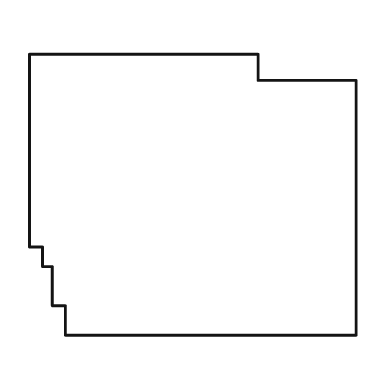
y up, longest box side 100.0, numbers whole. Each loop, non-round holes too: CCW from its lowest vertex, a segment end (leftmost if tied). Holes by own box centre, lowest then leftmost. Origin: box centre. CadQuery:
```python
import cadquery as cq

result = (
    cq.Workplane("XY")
    .moveTo(-39.0, -43.0)
    .lineTo(50.0, -43.0)
    .lineTo(50.0, 35.0)
    .lineTo(20.0, 35.0)
    .lineTo(20.0, 43.0)
    .lineTo(-50.0, 43.0)
    .lineTo(-50.0, -16.0)
    .lineTo(-46.0, -16.0)
    .lineTo(-46.0, -22.0)
    .lineTo(-43.0, -22.0)
    .lineTo(-43.0, -34.0)
    .lineTo(-39.0, -34.0)
    .close()
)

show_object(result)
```